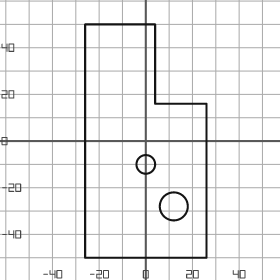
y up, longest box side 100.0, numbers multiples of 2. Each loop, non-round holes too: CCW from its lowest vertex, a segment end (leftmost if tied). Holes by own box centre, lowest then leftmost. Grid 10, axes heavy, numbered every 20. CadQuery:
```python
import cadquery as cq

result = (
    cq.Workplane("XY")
    .moveTo(-26.0, -50.0)
    .lineTo(26.0, -50.0)
    .lineTo(26.0, 16.0)
    .lineTo(4.0, 16.0)
    .lineTo(4.0, 50.0)
    .lineTo(-26.0, 50.0)
    .close()
    .moveTo(12.0, -28.0)
    .circle(6.0)
    .moveTo(0.0, -10.0)
    .circle(4.0)
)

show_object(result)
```